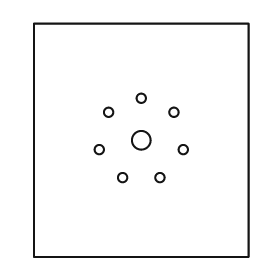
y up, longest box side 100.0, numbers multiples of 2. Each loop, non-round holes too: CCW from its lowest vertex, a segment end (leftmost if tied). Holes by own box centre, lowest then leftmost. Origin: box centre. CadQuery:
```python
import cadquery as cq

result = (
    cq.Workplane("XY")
    .moveTo(-46.0, -50.0)
    .lineTo(46.0, -50.0)
    .lineTo(46.0, 50.0)
    .lineTo(-46.0, 50.0)
    .close()
    .moveTo(-8.0, -16.0)
    .circle(2.0)
    .moveTo(8.0, -16.0)
    .circle(2.0)
    .moveTo(-18.0, -4.0)
    .circle(2.0)
    .moveTo(18.0, -4.0)
    .circle(2.0)
    .moveTo(0.0, 0.0)
    .circle(4.0)
    .moveTo(-14.0, 12.0)
    .circle(2.0)
    .moveTo(14.0, 12.0)
    .circle(2.0)
    .moveTo(0.0, 18.0)
    .circle(2.0)
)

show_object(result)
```